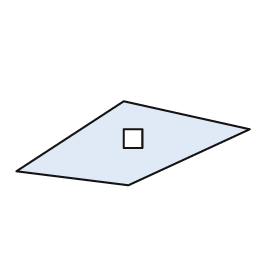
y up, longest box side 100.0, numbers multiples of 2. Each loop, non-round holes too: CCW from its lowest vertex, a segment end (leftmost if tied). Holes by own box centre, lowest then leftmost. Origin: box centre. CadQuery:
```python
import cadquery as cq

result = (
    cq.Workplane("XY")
    .moveTo(-2.0, -18.0)
    .lineTo(50.0, 6.0)
    .lineTo(-4.0, 18.0)
    .lineTo(-50.0, -12.0)
    .close()
    .moveTo(-4.0, -2.0)
    .lineTo(4.0, -2.0)
    .lineTo(4.0, 6.0)
    .lineTo(-4.0, 6.0)
    .close()
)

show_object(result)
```